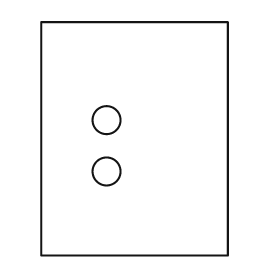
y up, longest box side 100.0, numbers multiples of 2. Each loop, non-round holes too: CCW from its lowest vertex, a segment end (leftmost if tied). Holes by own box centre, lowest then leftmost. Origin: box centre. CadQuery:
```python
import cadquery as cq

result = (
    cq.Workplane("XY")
    .moveTo(-40.0, -50.0)
    .lineTo(40.0, -50.0)
    .lineTo(40.0, 50.0)
    .lineTo(-40.0, 50.0)
    .close()
    .moveTo(-12.0, -14.0)
    .circle(6.0)
    .moveTo(-12.0, 8.0)
    .circle(6.0)
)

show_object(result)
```